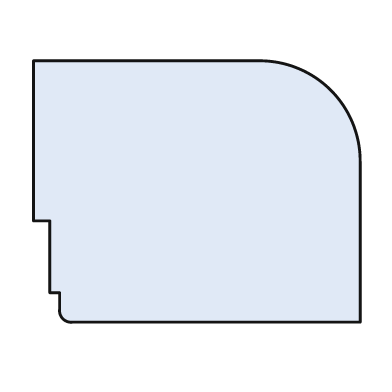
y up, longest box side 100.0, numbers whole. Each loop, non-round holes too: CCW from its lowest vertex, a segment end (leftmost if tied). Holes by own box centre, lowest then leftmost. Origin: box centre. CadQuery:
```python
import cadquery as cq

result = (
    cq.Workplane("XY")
    .moveTo(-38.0, -40.0)
    .lineTo(50.0, -40.0)
    .lineTo(50.0, 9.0)
    .threePointArc((41.0, 31.0), (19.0, 40.0))
    .lineTo(-50.0, 40.0)
    .lineTo(-50.0, -9.0)
    .lineTo(-45.0, -9.0)
    .lineTo(-45.0, -31.0)
    .lineTo(-42.0, -31.0)
    .lineTo(-42.0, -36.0)
    .threePointArc((-41.0, -39.0), (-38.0, -40.0))
    .close()
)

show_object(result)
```